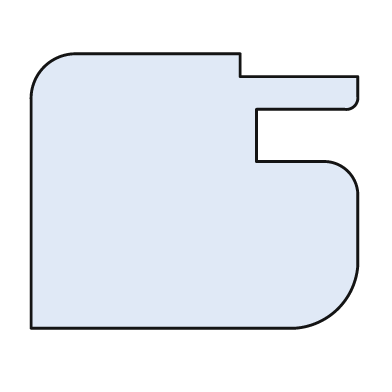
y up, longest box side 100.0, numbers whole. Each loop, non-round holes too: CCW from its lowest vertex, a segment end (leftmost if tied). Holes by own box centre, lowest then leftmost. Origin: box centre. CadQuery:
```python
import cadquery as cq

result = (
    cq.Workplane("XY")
    .moveTo(-50.0, -42.0)
    .lineTo(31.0, -42.0)
    .threePointArc((44.0, -36.0), (50.0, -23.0))
    .lineTo(50.0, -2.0)
    .threePointArc((47.0, 6.0), (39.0, 9.0))
    .lineTo(19.0, 9.0)
    .lineTo(19.0, 25.0)
    .lineTo(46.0, 25.0)
    .threePointArc((49.0, 26.0), (50.0, 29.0))
    .lineTo(50.0, 35.0)
    .lineTo(14.0, 35.0)
    .lineTo(14.0, 42.0)
    .lineTo(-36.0, 42.0)
    .threePointArc((-46.0, 38.0), (-50.0, 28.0))
    .close()
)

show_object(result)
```